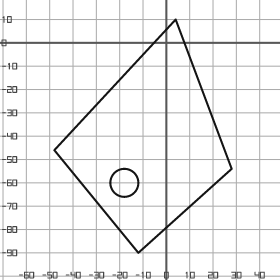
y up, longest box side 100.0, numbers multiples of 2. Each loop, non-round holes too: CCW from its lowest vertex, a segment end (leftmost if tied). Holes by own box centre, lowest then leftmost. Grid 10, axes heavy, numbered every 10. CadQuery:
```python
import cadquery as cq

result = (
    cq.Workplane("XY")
    .moveTo(-12.0, -90.0)
    .lineTo(28.0, -54.0)
    .lineTo(4.0, 10.0)
    .lineTo(-48.0, -46.0)
    .close()
    .moveTo(-18.0, -60.0)
    .circle(6.0)
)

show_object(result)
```